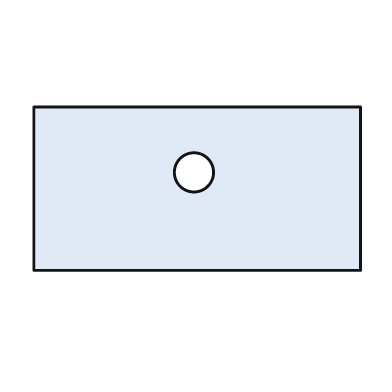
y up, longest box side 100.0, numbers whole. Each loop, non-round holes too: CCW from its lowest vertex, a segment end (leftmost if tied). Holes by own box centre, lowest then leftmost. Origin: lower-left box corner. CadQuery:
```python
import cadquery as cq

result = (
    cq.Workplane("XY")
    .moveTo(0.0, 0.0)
    .lineTo(100.0, 0.0)
    .lineTo(100.0, 50.0)
    .lineTo(0.0, 50.0)
    .close()
    .moveTo(49.0, 30.0)
    .circle(6.0)
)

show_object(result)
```